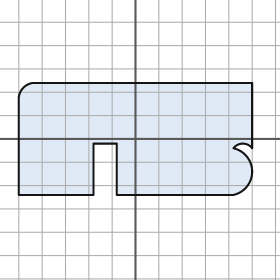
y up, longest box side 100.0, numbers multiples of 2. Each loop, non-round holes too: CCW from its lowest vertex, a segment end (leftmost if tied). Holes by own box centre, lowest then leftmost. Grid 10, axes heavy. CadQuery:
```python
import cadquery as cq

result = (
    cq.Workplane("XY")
    .moveTo(-50.0, -24.0)
    .lineTo(-18.0, -24.0)
    .lineTo(-18.0, -2.0)
    .lineTo(-8.0, -2.0)
    .lineTo(-8.0, -24.0)
    .lineTo(42.0, -24.0)
    .threePointArc((50.0, -14.0), (42.0, -4.0))
    .threePointArc((46.0, -2.0), (50.0, -4.0))
    .lineTo(50.0, 24.0)
    .lineTo(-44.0, 24.0)
    .threePointArc((-48.0, 22.0), (-50.0, 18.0))
    .close()
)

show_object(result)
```